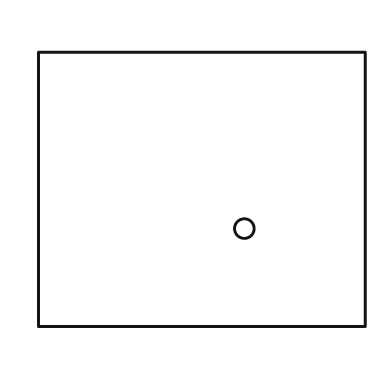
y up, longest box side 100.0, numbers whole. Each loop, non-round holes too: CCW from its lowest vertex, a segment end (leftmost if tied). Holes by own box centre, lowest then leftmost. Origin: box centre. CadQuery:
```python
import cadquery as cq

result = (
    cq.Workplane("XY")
    .moveTo(-50.0, -42.0)
    .lineTo(50.0, -42.0)
    .lineTo(50.0, 42.0)
    .lineTo(-50.0, 42.0)
    .close()
    .moveTo(13.0, -12.0)
    .circle(3.0)
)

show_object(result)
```